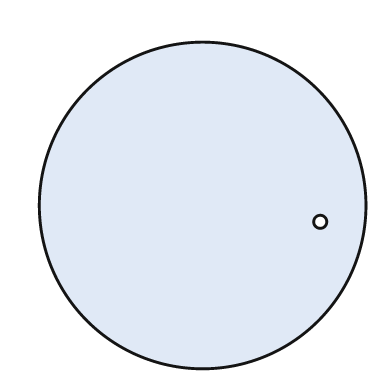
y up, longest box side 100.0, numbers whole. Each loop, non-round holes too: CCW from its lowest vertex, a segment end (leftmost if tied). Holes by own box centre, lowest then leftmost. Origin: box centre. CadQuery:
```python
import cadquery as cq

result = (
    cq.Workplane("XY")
    .moveTo(0.0, 0.0)
    .circle(50.0)
    .moveTo(36.0, -5.0)
    .circle(2.0)
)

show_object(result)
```